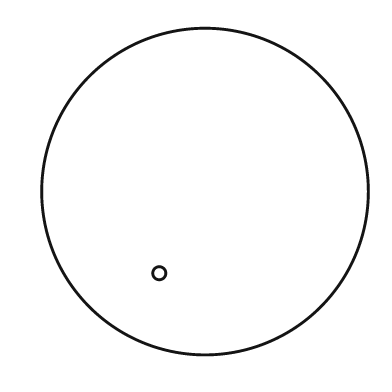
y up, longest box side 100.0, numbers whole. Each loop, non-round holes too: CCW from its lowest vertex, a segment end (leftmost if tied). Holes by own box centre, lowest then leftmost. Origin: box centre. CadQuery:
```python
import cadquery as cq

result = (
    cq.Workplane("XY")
    .moveTo(0.0, 0.0)
    .circle(50.0)
    .moveTo(-14.0, -25.0)
    .circle(2.0)
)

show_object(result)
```